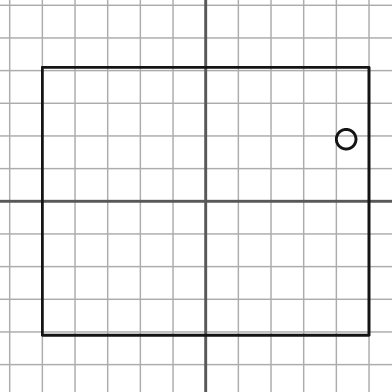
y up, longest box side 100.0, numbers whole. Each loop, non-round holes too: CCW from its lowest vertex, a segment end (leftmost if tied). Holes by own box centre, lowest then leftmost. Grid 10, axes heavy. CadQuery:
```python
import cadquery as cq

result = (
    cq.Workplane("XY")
    .moveTo(-50.0, -41.0)
    .lineTo(50.0, -41.0)
    .lineTo(50.0, 41.0)
    .lineTo(-50.0, 41.0)
    .close()
    .moveTo(43.0, 19.0)
    .circle(3.0)
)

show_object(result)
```